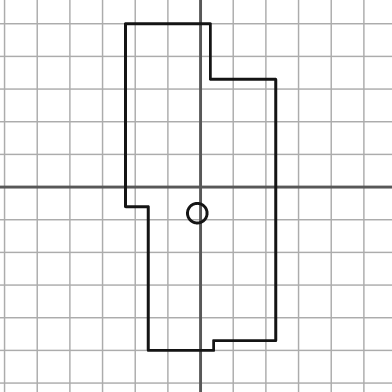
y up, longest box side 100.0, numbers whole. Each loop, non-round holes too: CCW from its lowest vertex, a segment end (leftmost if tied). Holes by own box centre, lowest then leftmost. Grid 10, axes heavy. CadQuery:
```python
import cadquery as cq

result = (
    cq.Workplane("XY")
    .moveTo(-16.0, -50.0)
    .lineTo(4.0, -50.0)
    .lineTo(4.0, -47.0)
    .lineTo(23.0, -47.0)
    .lineTo(23.0, 33.0)
    .lineTo(3.0, 33.0)
    .lineTo(3.0, 50.0)
    .lineTo(-23.0, 50.0)
    .lineTo(-23.0, -6.0)
    .lineTo(-16.0, -6.0)
    .close()
    .moveTo(-1.0, -8.0)
    .circle(3.0)
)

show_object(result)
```